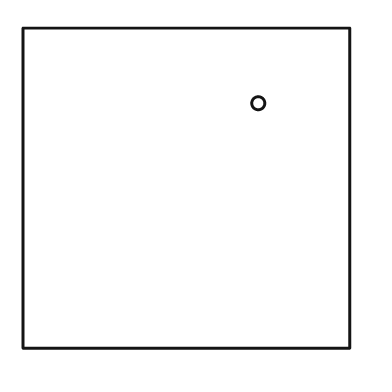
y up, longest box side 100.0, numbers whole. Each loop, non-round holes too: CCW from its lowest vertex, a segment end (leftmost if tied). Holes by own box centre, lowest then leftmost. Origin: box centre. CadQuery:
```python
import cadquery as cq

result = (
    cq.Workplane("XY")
    .moveTo(-50.0, -49.0)
    .lineTo(50.0, -49.0)
    .lineTo(50.0, 49.0)
    .lineTo(-50.0, 49.0)
    .close()
    .moveTo(22.0, 26.0)
    .circle(2.0)
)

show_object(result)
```